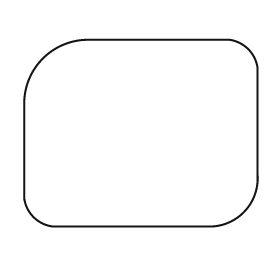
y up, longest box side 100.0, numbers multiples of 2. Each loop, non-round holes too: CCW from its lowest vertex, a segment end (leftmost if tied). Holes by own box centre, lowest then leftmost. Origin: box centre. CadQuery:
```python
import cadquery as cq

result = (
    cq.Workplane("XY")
    .moveTo(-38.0, -40.0)
    .lineTo(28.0, -40.0)
    .threePointArc((44.0, -34.0), (50.0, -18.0))
    .lineTo(50.0, 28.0)
    .threePointArc((46.0, 36.0), (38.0, 40.0))
    .lineTo(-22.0, 40.0)
    .threePointArc((-42.0, 32.0), (-50.0, 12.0))
    .lineTo(-50.0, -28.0)
    .threePointArc((-46.0, -36.0), (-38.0, -40.0))
    .close()
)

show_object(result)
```